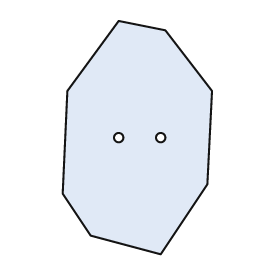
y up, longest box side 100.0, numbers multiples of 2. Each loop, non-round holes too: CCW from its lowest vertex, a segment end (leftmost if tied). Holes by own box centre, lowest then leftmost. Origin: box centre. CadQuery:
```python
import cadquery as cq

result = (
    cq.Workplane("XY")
    .moveTo(10.0, -50.0)
    .lineTo(30.0, -20.0)
    .lineTo(32.0, 20.0)
    .lineTo(12.0, 46.0)
    .lineTo(-8.0, 50.0)
    .lineTo(-30.0, 20.0)
    .lineTo(-32.0, -24.0)
    .lineTo(-20.0, -42.0)
    .close()
    .moveTo(-8.0, 0.0)
    .circle(2.0)
    .moveTo(10.0, 0.0)
    .circle(2.0)
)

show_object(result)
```